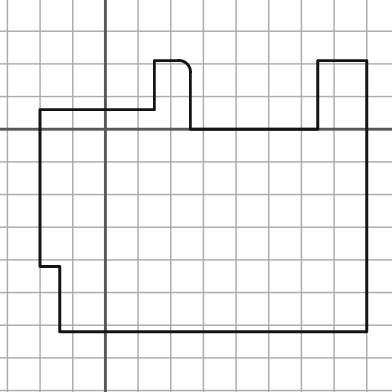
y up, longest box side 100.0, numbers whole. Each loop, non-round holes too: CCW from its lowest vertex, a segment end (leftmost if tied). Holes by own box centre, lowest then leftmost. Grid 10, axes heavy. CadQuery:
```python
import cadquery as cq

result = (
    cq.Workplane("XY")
    .moveTo(-14.0, -62.0)
    .lineTo(80.0, -62.0)
    .lineTo(80.0, 21.0)
    .lineTo(65.0, 21.0)
    .lineTo(65.0, 0.0)
    .lineTo(26.0, 0.0)
    .lineTo(26.0, 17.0)
    .threePointArc((25.0, 20.0), (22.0, 21.0))
    .lineTo(15.0, 21.0)
    .lineTo(15.0, 6.0)
    .lineTo(-20.0, 6.0)
    .lineTo(-20.0, -42.0)
    .lineTo(-14.0, -42.0)
    .close()
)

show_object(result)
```